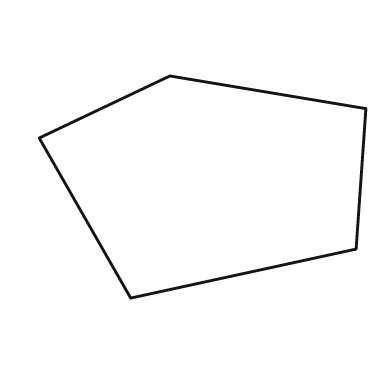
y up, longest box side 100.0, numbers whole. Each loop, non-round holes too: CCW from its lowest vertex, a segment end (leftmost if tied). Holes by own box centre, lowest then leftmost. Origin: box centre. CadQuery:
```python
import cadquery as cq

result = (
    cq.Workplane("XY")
    .moveTo(-22.0, -34.0)
    .lineTo(47.0, -19.0)
    .lineTo(50.0, 24.0)
    .lineTo(-10.0, 34.0)
    .lineTo(-50.0, 15.0)
    .close()
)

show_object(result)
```